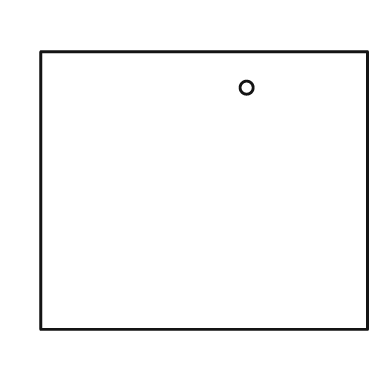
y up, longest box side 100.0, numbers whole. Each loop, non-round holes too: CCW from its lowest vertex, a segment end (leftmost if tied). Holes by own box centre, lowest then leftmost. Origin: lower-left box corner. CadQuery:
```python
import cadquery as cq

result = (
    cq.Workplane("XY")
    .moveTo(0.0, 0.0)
    .lineTo(100.0, 0.0)
    .lineTo(100.0, 85.0)
    .lineTo(0.0, 85.0)
    .close()
    .moveTo(63.0, 74.0)
    .circle(2.0)
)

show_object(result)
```